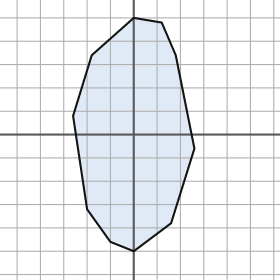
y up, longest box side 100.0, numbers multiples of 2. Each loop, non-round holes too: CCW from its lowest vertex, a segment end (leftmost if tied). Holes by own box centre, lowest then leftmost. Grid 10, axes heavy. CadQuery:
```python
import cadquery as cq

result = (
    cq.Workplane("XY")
    .moveTo(0.0, -50.0)
    .lineTo(16.0, -38.0)
    .lineTo(26.0, -6.0)
    .lineTo(18.0, 34.0)
    .lineTo(12.0, 48.0)
    .lineTo(0.0, 50.0)
    .lineTo(-18.0, 34.0)
    .lineTo(-26.0, 8.0)
    .lineTo(-20.0, -32.0)
    .lineTo(-10.0, -46.0)
    .close()
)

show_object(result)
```